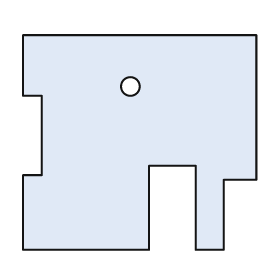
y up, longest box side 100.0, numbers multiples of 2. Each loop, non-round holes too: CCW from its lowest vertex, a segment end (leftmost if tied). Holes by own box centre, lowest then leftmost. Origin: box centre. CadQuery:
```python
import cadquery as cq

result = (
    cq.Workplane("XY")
    .moveTo(-50.0, -46.0)
    .lineTo(4.0, -46.0)
    .lineTo(4.0, -10.0)
    .lineTo(24.0, -10.0)
    .lineTo(24.0, -46.0)
    .lineTo(36.0, -46.0)
    .lineTo(36.0, -16.0)
    .lineTo(50.0, -16.0)
    .lineTo(50.0, 46.0)
    .lineTo(-50.0, 46.0)
    .lineTo(-50.0, 20.0)
    .lineTo(-42.0, 20.0)
    .lineTo(-42.0, -14.0)
    .lineTo(-50.0, -14.0)
    .close()
    .moveTo(-4.0, 24.0)
    .circle(4.0)
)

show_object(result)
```